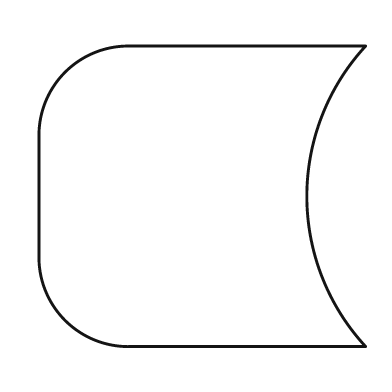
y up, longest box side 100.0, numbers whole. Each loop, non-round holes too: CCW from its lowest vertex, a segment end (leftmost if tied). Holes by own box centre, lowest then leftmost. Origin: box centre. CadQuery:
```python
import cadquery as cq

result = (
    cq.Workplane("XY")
    .moveTo(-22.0, -46.0)
    .lineTo(50.0, -46.0)
    .threePointArc((32.0, 0.0), (50.0, 46.0))
    .lineTo(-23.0, 46.0)
    .threePointArc((-42.0, 38.0), (-50.0, 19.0))
    .lineTo(-50.0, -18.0)
    .threePointArc((-42.0, -38.0), (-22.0, -46.0))
    .close()
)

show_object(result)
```